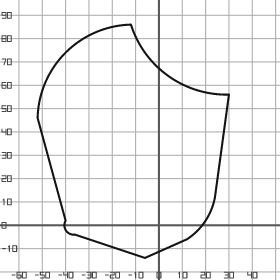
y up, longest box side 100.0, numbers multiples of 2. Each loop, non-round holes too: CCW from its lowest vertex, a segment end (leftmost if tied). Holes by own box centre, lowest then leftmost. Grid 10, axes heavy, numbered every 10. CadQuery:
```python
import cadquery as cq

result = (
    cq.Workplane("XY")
    .moveTo(-6.0, -14.0)
    .lineTo(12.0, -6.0)
    .threePointArc((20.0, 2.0), (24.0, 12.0))
    .lineTo(30.0, 56.0)
    .threePointArc((4.0, 64.0), (-12.0, 86.0))
    .threePointArc((-40.0, 74.0), (-52.0, 46.0))
    .lineTo(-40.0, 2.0)
    .threePointArc((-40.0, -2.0), (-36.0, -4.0))
    .close()
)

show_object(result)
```